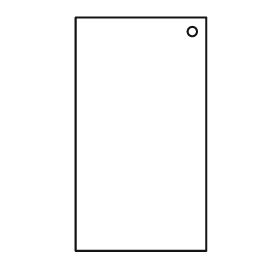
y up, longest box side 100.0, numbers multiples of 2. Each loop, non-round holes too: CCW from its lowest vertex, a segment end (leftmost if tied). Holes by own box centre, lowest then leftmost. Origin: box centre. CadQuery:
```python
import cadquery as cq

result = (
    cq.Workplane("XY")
    .moveTo(-28.0, -50.0)
    .lineTo(28.0, -50.0)
    .lineTo(28.0, 50.0)
    .lineTo(-28.0, 50.0)
    .close()
    .moveTo(22.0, 44.0)
    .circle(2.0)
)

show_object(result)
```